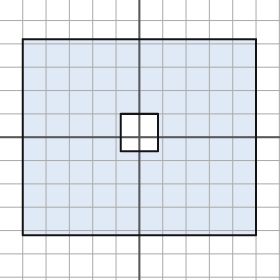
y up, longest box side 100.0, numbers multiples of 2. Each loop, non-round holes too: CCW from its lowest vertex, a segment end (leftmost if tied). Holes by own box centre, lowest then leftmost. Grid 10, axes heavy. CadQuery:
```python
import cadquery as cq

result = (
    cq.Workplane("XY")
    .moveTo(-50.0, -42.0)
    .lineTo(50.0, -42.0)
    .lineTo(50.0, 42.0)
    .lineTo(-50.0, 42.0)
    .close()
    .moveTo(-8.0, -6.0)
    .lineTo(8.0, -6.0)
    .lineTo(8.0, 10.0)
    .lineTo(-8.0, 10.0)
    .close()
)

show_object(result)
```